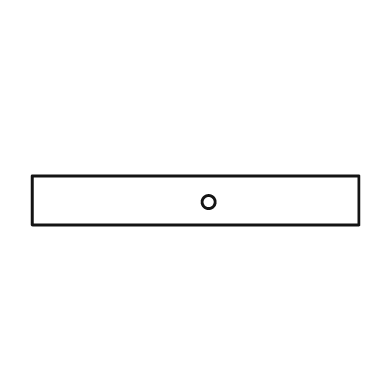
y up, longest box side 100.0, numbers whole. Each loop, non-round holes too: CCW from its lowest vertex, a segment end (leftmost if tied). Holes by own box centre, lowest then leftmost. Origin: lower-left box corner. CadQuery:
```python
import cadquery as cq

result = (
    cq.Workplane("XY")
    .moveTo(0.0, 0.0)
    .lineTo(100.0, 0.0)
    .lineTo(100.0, 15.0)
    .lineTo(0.0, 15.0)
    .close()
    .moveTo(54.0, 7.0)
    .circle(2.0)
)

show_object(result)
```